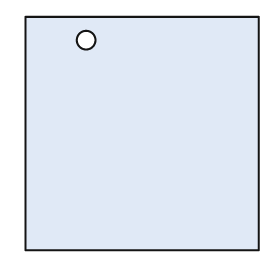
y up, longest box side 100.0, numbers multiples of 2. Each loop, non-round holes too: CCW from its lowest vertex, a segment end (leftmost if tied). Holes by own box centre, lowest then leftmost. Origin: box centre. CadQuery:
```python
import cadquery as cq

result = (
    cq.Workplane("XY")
    .moveTo(-50.0, -50.0)
    .lineTo(50.0, -50.0)
    .lineTo(50.0, 50.0)
    .lineTo(-50.0, 50.0)
    .close()
    .moveTo(-24.0, 40.0)
    .circle(4.0)
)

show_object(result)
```